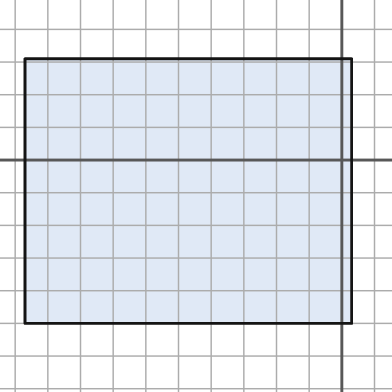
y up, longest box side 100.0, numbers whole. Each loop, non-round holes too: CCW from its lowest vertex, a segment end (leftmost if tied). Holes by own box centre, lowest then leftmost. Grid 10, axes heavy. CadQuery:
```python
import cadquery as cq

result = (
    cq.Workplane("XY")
    .moveTo(-97.0, -50.0)
    .lineTo(3.0, -50.0)
    .lineTo(3.0, 31.0)
    .lineTo(-97.0, 31.0)
    .close()
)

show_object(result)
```